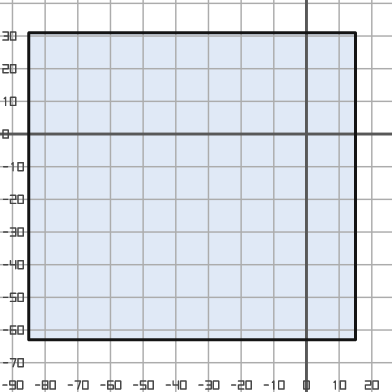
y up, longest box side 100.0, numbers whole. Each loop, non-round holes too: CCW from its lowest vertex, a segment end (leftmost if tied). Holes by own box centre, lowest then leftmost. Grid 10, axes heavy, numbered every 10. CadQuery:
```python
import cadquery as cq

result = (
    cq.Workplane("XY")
    .moveTo(-85.0, -63.0)
    .lineTo(15.0, -63.0)
    .lineTo(15.0, 31.0)
    .lineTo(-85.0, 31.0)
    .close()
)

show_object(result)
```